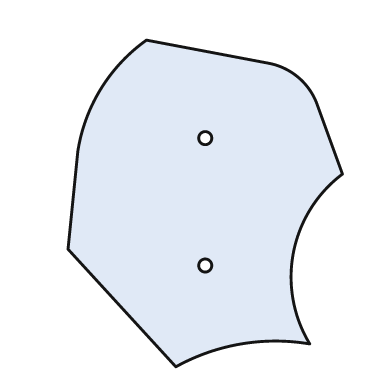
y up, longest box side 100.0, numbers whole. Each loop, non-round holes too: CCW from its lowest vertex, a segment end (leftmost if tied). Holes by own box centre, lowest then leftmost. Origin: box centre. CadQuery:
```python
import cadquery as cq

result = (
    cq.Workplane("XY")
    .moveTo(-9.0, -50.0)
    .threePointArc((11.0, -43.0), (32.0, -43.0))
    .threePointArc((27.0, -15.0), (42.0, 9.0))
    .lineTo(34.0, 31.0)
    .threePointArc((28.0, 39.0), (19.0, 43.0))
    .lineTo(-18.0, 50.0)
    .threePointArc((-32.0, 35.0), (-39.0, 16.0))
    .lineTo(-42.0, -14.0)
    .close()
    .moveTo(0.0, -19.0)
    .circle(2.0)
    .moveTo(0.0, 20.0)
    .circle(2.0)
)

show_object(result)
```